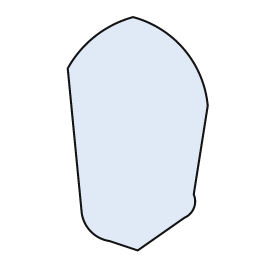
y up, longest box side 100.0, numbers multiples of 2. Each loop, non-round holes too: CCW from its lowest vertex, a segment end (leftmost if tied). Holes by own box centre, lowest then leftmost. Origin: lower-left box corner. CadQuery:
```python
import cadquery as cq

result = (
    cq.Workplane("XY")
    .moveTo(30.0, 0.0)
    .lineTo(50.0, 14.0)
    .threePointArc((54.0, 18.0), (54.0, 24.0))
    .lineTo(60.0, 62.0)
    .threePointArc((50.0, 86.0), (28.0, 100.0))
    .threePointArc((12.0, 92.0), (0.0, 78.0))
    .lineTo(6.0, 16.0)
    .threePointArc((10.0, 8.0), (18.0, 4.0))
    .close()
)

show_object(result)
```